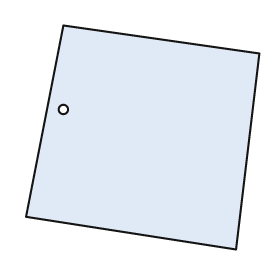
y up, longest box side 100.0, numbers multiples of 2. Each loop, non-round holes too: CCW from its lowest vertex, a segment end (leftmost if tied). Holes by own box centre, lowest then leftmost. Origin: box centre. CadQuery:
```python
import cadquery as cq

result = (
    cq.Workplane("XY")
    .moveTo(40.0, -48.0)
    .lineTo(50.0, 36.0)
    .lineTo(-34.0, 48.0)
    .lineTo(-50.0, -34.0)
    .close()
    .moveTo(-34.0, 12.0)
    .circle(2.0)
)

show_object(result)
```